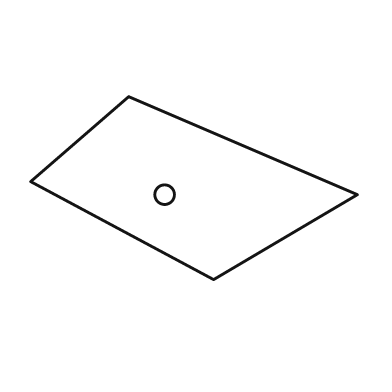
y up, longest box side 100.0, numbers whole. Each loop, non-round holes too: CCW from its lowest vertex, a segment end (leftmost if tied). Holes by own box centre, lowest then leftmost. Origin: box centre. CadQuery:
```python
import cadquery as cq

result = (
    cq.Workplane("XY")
    .moveTo(6.0, -28.0)
    .lineTo(50.0, -2.0)
    .lineTo(-20.0, 28.0)
    .lineTo(-50.0, 2.0)
    .close()
    .moveTo(-9.0, -2.0)
    .circle(3.0)
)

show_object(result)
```